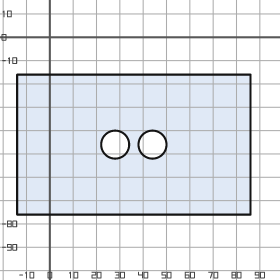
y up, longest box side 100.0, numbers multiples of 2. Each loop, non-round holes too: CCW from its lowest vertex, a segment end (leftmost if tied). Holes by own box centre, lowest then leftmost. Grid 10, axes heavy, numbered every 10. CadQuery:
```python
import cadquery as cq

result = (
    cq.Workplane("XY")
    .moveTo(-14.0, -76.0)
    .lineTo(86.0, -76.0)
    .lineTo(86.0, -16.0)
    .lineTo(-14.0, -16.0)
    .close()
    .moveTo(28.0, -46.0)
    .circle(6.0)
    .moveTo(44.0, -46.0)
    .circle(6.0)
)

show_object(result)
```